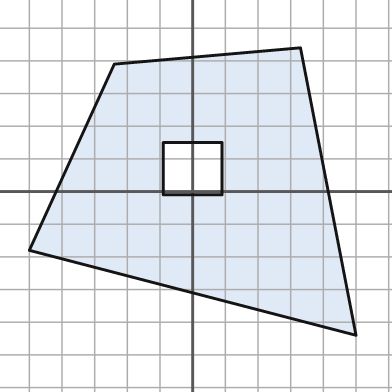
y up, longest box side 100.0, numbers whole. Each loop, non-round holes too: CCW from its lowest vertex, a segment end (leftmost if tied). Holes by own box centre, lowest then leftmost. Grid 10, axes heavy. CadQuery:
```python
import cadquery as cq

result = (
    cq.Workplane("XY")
    .moveTo(50.0, -44.0)
    .lineTo(33.0, 44.0)
    .lineTo(-24.0, 39.0)
    .lineTo(-50.0, -18.0)
    .close()
    .moveTo(-9.0, -1.0)
    .lineTo(9.0, -1.0)
    .lineTo(9.0, 15.0)
    .lineTo(-9.0, 15.0)
    .close()
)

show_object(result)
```